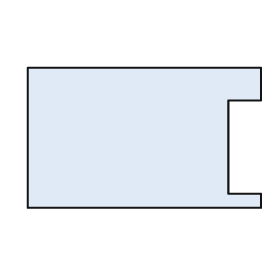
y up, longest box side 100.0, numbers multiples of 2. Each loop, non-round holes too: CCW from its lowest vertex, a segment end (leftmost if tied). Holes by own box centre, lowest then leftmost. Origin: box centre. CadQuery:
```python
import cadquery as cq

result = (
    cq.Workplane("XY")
    .moveTo(-50.0, -30.0)
    .lineTo(50.0, -30.0)
    .lineTo(50.0, -24.0)
    .lineTo(36.0, -24.0)
    .lineTo(36.0, 16.0)
    .lineTo(50.0, 16.0)
    .lineTo(50.0, 30.0)
    .lineTo(-50.0, 30.0)
    .close()
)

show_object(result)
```